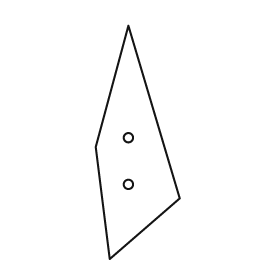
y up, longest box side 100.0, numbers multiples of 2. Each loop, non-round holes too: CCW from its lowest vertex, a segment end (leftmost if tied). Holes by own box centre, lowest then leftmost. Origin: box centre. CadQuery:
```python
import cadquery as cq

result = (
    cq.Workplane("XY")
    .moveTo(-12.0, -50.0)
    .lineTo(18.0, -24.0)
    .lineTo(-4.0, 50.0)
    .lineTo(-18.0, -2.0)
    .close()
    .moveTo(-4.0, -18.0)
    .circle(2.0)
    .moveTo(-4.0, 2.0)
    .circle(2.0)
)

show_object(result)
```